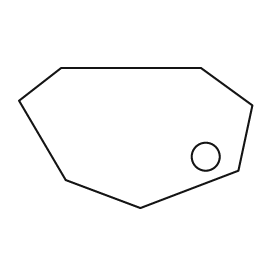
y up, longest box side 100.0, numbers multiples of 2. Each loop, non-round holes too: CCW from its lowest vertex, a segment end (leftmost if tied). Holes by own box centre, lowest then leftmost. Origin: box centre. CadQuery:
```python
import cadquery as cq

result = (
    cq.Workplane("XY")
    .moveTo(2.0, -30.0)
    .lineTo(44.0, -14.0)
    .lineTo(50.0, 14.0)
    .lineTo(28.0, 30.0)
    .lineTo(-32.0, 30.0)
    .lineTo(-50.0, 16.0)
    .lineTo(-30.0, -18.0)
    .close()
    .moveTo(30.0, -8.0)
    .circle(6.0)
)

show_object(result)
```